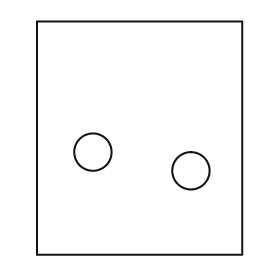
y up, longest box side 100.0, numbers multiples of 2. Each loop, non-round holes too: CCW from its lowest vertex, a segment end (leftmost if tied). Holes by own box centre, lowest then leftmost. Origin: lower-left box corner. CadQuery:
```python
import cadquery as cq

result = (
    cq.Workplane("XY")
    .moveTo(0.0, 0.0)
    .lineTo(88.0, 0.0)
    .lineTo(88.0, 100.0)
    .lineTo(0.0, 100.0)
    .close()
    .moveTo(66.0, 36.0)
    .circle(8.0)
    .moveTo(24.0, 44.0)
    .circle(8.0)
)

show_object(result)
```